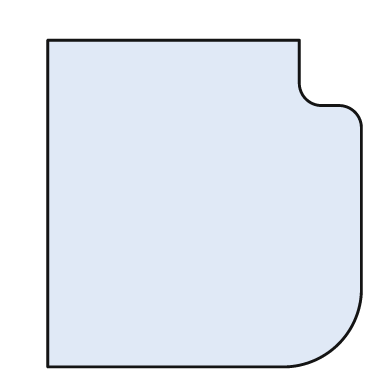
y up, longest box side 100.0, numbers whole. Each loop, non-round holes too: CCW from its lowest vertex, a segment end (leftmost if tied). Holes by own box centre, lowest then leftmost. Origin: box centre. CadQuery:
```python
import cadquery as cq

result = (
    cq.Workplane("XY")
    .moveTo(-48.0, -50.0)
    .lineTo(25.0, -50.0)
    .threePointArc((41.0, -43.0), (48.0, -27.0))
    .lineTo(48.0, 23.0)
    .threePointArc((46.0, 28.0), (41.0, 30.0))
    .lineTo(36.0, 30.0)
    .threePointArc((31.0, 32.0), (29.0, 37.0))
    .lineTo(29.0, 50.0)
    .lineTo(-48.0, 50.0)
    .close()
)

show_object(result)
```